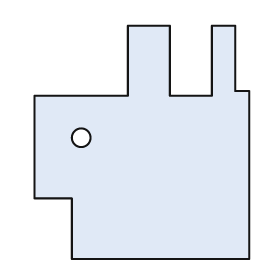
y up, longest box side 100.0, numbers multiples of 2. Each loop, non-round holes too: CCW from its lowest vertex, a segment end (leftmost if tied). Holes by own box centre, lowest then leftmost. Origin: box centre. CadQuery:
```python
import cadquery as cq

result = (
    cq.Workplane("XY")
    .moveTo(-30.0, -50.0)
    .lineTo(46.0, -50.0)
    .lineTo(46.0, 22.0)
    .lineTo(40.0, 22.0)
    .lineTo(40.0, 50.0)
    .lineTo(30.0, 50.0)
    .lineTo(30.0, 20.0)
    .lineTo(12.0, 20.0)
    .lineTo(12.0, 50.0)
    .lineTo(-6.0, 50.0)
    .lineTo(-6.0, 20.0)
    .lineTo(-46.0, 20.0)
    .lineTo(-46.0, -24.0)
    .lineTo(-30.0, -24.0)
    .close()
    .moveTo(-26.0, 2.0)
    .circle(4.0)
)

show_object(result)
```